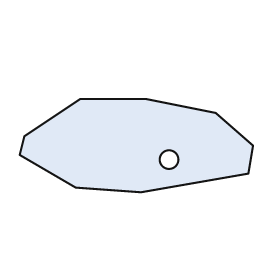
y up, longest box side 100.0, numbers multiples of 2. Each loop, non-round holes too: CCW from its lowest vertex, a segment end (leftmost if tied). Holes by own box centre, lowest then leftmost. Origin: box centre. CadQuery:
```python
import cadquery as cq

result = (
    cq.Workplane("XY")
    .moveTo(2.0, -20.0)
    .lineTo(48.0, -12.0)
    .lineTo(50.0, 0.0)
    .lineTo(34.0, 14.0)
    .lineTo(4.0, 20.0)
    .lineTo(-24.0, 20.0)
    .lineTo(-48.0, 4.0)
    .lineTo(-50.0, -4.0)
    .lineTo(-26.0, -18.0)
    .close()
    .moveTo(14.0, -6.0)
    .circle(4.0)
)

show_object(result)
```